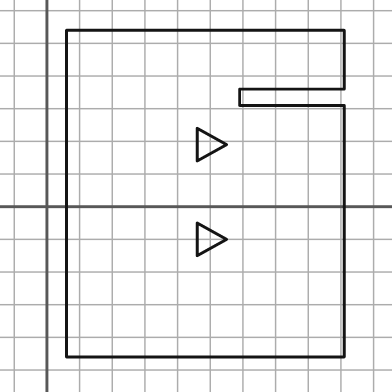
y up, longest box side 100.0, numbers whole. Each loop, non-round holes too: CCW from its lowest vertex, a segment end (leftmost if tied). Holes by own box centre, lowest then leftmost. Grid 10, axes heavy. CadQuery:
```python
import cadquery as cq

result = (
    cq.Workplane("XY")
    .moveTo(6.0, -46.0)
    .lineTo(91.0, -46.0)
    .lineTo(91.0, 31.0)
    .lineTo(59.0, 31.0)
    .lineTo(59.0, 36.0)
    .lineTo(91.0, 36.0)
    .lineTo(91.0, 54.0)
    .lineTo(6.0, 54.0)
    .close()
    .moveTo(46.0, -15.0)
    .lineTo(55.0, -10.0)
    .lineTo(46.0, -5.0)
    .close()
    .moveTo(46.0, 14.0)
    .lineTo(55.0, 19.0)
    .lineTo(46.0, 24.0)
    .close()
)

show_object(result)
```